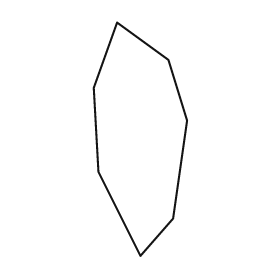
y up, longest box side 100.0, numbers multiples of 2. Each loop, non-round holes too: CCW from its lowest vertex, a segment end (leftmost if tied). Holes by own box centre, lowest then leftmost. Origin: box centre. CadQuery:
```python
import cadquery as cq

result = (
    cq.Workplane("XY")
    .moveTo(0.0, -50.0)
    .lineTo(14.0, -34.0)
    .lineTo(20.0, 8.0)
    .lineTo(12.0, 34.0)
    .lineTo(-10.0, 50.0)
    .lineTo(-20.0, 22.0)
    .lineTo(-18.0, -14.0)
    .close()
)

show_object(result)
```